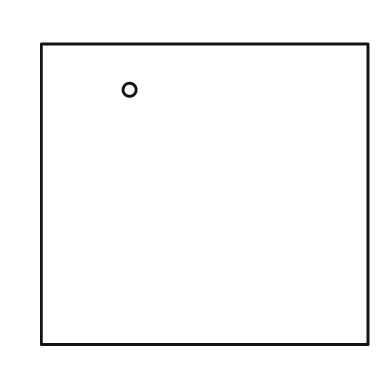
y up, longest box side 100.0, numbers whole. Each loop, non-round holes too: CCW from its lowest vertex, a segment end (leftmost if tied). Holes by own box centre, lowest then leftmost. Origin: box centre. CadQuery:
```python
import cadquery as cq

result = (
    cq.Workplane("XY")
    .moveTo(-50.0, -46.0)
    .lineTo(50.0, -46.0)
    .lineTo(50.0, 46.0)
    .lineTo(-50.0, 46.0)
    .close()
    .moveTo(-23.0, 32.0)
    .circle(2.0)
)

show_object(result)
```